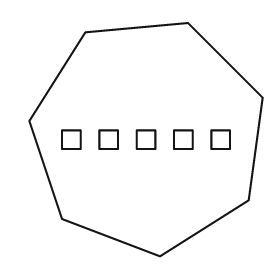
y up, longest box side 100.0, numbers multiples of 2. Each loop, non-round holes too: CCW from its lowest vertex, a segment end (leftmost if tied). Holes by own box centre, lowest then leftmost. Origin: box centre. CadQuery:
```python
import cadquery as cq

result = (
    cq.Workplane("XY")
    .moveTo(6.0, -50.0)
    .lineTo(44.0, -26.0)
    .lineTo(50.0, 18.0)
    .lineTo(18.0, 50.0)
    .lineTo(-26.0, 46.0)
    .lineTo(-50.0, 8.0)
    .lineTo(-36.0, -34.0)
    .close()
    .moveTo(-36.0, -4.0)
    .lineTo(-28.0, -4.0)
    .lineTo(-28.0, 4.0)
    .lineTo(-36.0, 4.0)
    .close()
    .moveTo(-20.0, -4.0)
    .lineTo(-12.0, -4.0)
    .lineTo(-12.0, 4.0)
    .lineTo(-20.0, 4.0)
    .close()
    .moveTo(-4.0, -4.0)
    .lineTo(4.0, -4.0)
    .lineTo(4.0, 4.0)
    .lineTo(-4.0, 4.0)
    .close()
    .moveTo(12.0, -4.0)
    .lineTo(20.0, -4.0)
    .lineTo(20.0, 4.0)
    .lineTo(12.0, 4.0)
    .close()
    .moveTo(28.0, -4.0)
    .lineTo(36.0, -4.0)
    .lineTo(36.0, 4.0)
    .lineTo(28.0, 4.0)
    .close()
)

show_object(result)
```